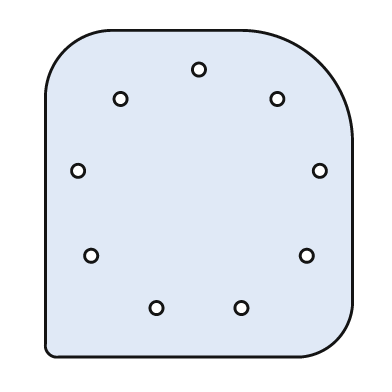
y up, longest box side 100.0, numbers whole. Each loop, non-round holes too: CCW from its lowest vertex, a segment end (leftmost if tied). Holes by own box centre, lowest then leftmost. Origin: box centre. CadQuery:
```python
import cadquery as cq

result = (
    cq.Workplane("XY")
    .moveTo(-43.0, -50.0)
    .lineTo(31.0, -50.0)
    .threePointArc((42.0, -45.0), (47.0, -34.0))
    .lineTo(47.0, 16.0)
    .threePointArc((37.0, 40.0), (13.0, 50.0))
    .lineTo(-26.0, 50.0)
    .threePointArc((-41.0, 44.0), (-47.0, 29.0))
    .lineTo(-47.0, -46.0)
    .threePointArc((-46.0, -49.0), (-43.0, -50.0))
    .close()
    .moveTo(-13.0, -35.0)
    .circle(2.0)
    .moveTo(13.0, -35.0)
    .circle(2.0)
    .moveTo(-33.0, -19.0)
    .circle(2.0)
    .moveTo(33.0, -19.0)
    .circle(2.0)
    .moveTo(-37.0, 7.0)
    .circle(2.0)
    .moveTo(37.0, 7.0)
    .circle(2.0)
    .moveTo(-24.0, 29.0)
    .circle(2.0)
    .moveTo(24.0, 29.0)
    .circle(2.0)
    .moveTo(0.0, 38.0)
    .circle(2.0)
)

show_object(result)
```